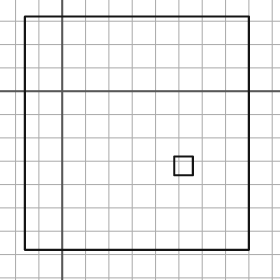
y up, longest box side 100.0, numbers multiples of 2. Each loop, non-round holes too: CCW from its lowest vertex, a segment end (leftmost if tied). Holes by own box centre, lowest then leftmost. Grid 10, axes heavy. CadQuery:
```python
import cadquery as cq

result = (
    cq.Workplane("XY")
    .moveTo(-16.0, -68.0)
    .lineTo(80.0, -68.0)
    .lineTo(80.0, 32.0)
    .lineTo(-16.0, 32.0)
    .close()
    .moveTo(48.0, -36.0)
    .lineTo(56.0, -36.0)
    .lineTo(56.0, -28.0)
    .lineTo(48.0, -28.0)
    .close()
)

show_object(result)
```